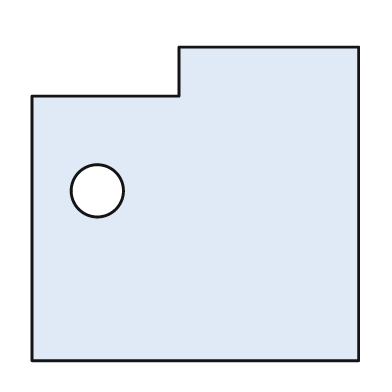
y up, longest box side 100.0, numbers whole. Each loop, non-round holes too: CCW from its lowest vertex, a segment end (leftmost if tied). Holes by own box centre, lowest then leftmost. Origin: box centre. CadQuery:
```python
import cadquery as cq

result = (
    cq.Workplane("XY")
    .moveTo(-50.0, -48.0)
    .lineTo(50.0, -48.0)
    .lineTo(50.0, 48.0)
    .lineTo(-5.0, 48.0)
    .lineTo(-5.0, 33.0)
    .lineTo(-50.0, 33.0)
    .close()
    .moveTo(-30.0, 4.0)
    .circle(8.0)
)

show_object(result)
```